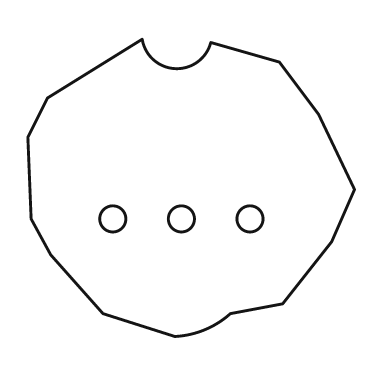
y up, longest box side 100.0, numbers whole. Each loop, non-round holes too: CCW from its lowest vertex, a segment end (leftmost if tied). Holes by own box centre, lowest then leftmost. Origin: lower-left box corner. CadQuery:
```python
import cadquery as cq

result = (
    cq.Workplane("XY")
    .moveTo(45.0, 0.0)
    .threePointArc((54.0, 2.0), (62.0, 7.0))
    .lineTo(78.0, 10.0)
    .lineTo(93.0, 29.0)
    .lineTo(100.0, 45.0)
    .lineTo(89.0, 68.0)
    .lineTo(77.0, 84.0)
    .lineTo(56.0, 90.0)
    .threePointArc((45.0, 82.0), (35.0, 91.0))
    .lineTo(6.0, 73.0)
    .lineTo(0.0, 61.0)
    .lineTo(1.0, 36.0)
    .lineTo(7.0, 25.0)
    .lineTo(23.0, 7.0)
    .close()
    .moveTo(26.0, 36.0)
    .circle(4.0)
    .moveTo(47.0, 36.0)
    .circle(4.0)
    .moveTo(68.0, 36.0)
    .circle(4.0)
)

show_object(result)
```